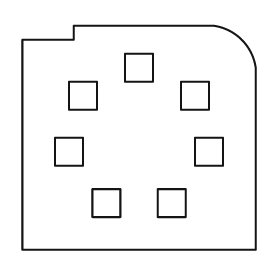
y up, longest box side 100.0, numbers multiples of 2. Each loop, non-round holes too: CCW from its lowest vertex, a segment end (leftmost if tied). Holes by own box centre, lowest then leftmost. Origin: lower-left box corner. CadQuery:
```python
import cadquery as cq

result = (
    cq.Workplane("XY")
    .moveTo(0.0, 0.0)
    .lineTo(100.0, 0.0)
    .lineTo(100.0, 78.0)
    .threePointArc((94.0, 90.0), (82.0, 96.0))
    .lineTo(22.0, 96.0)
    .lineTo(22.0, 90.0)
    .lineTo(0.0, 90.0)
    .close()
    .moveTo(30.0, 14.0)
    .lineTo(42.0, 14.0)
    .lineTo(42.0, 26.0)
    .lineTo(30.0, 26.0)
    .close()
    .moveTo(58.0, 14.0)
    .lineTo(70.0, 14.0)
    .lineTo(70.0, 26.0)
    .lineTo(58.0, 26.0)
    .close()
    .moveTo(14.0, 36.0)
    .lineTo(26.0, 36.0)
    .lineTo(26.0, 48.0)
    .lineTo(14.0, 48.0)
    .close()
    .moveTo(74.0, 36.0)
    .lineTo(86.0, 36.0)
    .lineTo(86.0, 48.0)
    .lineTo(74.0, 48.0)
    .close()
    .moveTo(20.0, 60.0)
    .lineTo(32.0, 60.0)
    .lineTo(32.0, 72.0)
    .lineTo(20.0, 72.0)
    .close()
    .moveTo(68.0, 60.0)
    .lineTo(80.0, 60.0)
    .lineTo(80.0, 72.0)
    .lineTo(68.0, 72.0)
    .close()
    .moveTo(44.0, 72.0)
    .lineTo(56.0, 72.0)
    .lineTo(56.0, 84.0)
    .lineTo(44.0, 84.0)
    .close()
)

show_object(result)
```